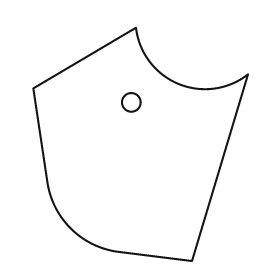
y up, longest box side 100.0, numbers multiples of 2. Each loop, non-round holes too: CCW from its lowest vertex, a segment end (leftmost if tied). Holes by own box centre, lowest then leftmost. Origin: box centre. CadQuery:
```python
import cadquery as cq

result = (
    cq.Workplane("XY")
    .moveTo(22.0, -50.0)
    .lineTo(46.0, 30.0)
    .threePointArc((16.0, 26.0), (-2.0, 50.0))
    .lineTo(-46.0, 24.0)
    .lineTo(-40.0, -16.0)
    .threePointArc((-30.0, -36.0), (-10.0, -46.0))
    .close()
    .moveTo(-4.0, 18.0)
    .circle(4.0)
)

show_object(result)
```